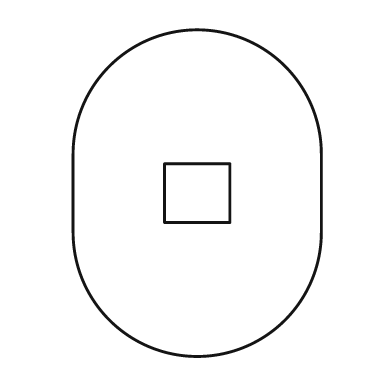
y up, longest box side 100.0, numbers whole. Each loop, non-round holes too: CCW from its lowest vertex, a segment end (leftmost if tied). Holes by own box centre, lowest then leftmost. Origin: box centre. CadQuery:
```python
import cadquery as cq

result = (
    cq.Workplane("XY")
    .moveTo(-38.0, -12.0)
    .threePointArc((0.0, -50.0), (38.0, -12.0))
    .lineTo(38.0, 12.0)
    .threePointArc((0.0, 50.0), (-38.0, 12.0))
    .close()
    .moveTo(-10.0, -9.0)
    .lineTo(10.0, -9.0)
    .lineTo(10.0, 9.0)
    .lineTo(-10.0, 9.0)
    .close()
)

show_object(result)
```